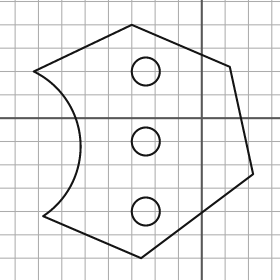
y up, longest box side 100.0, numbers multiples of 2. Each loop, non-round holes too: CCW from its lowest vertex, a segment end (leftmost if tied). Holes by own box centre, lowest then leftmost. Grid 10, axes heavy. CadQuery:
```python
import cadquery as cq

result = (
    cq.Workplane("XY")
    .moveTo(-26.0, -60.0)
    .lineTo(22.0, -24.0)
    .lineTo(12.0, 22.0)
    .lineTo(-30.0, 40.0)
    .lineTo(-72.0, 20.0)
    .threePointArc((-52.0, -10.0), (-68.0, -42.0))
    .close()
    .moveTo(-24.0, -40.0)
    .circle(6.0)
    .moveTo(-24.0, -10.0)
    .circle(6.0)
    .moveTo(-24.0, 20.0)
    .circle(6.0)
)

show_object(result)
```